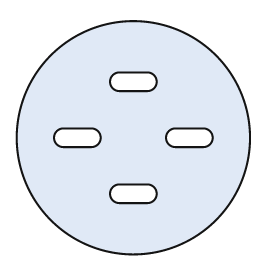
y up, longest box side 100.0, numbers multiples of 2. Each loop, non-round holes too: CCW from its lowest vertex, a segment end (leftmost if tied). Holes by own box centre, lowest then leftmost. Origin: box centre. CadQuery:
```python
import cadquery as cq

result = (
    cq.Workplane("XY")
    .moveTo(0.0, 0.0)
    .circle(50.0)
    .moveTo(-6.0, -28.0)
    .lineTo(6.0, -28.0)
    .threePointArc((10.0, -24.0), (6.0, -20.0))
    .lineTo(-6.0, -20.0)
    .threePointArc((-10.0, -24.0), (-6.0, -28.0))
    .close()
    .moveTo(-30.0, -4.0)
    .lineTo(-18.0, -4.0)
    .threePointArc((-14.0, 0.0), (-18.0, 4.0))
    .lineTo(-30.0, 4.0)
    .threePointArc((-34.0, 0.0), (-30.0, -4.0))
    .close()
    .moveTo(18.0, -4.0)
    .lineTo(30.0, -4.0)
    .threePointArc((34.0, 0.0), (30.0, 4.0))
    .lineTo(18.0, 4.0)
    .threePointArc((14.0, 0.0), (18.0, -4.0))
    .close()
    .moveTo(-6.0, 20.0)
    .lineTo(6.0, 20.0)
    .threePointArc((10.0, 24.0), (6.0, 28.0))
    .lineTo(-6.0, 28.0)
    .threePointArc((-10.0, 24.0), (-6.0, 20.0))
    .close()
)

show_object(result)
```